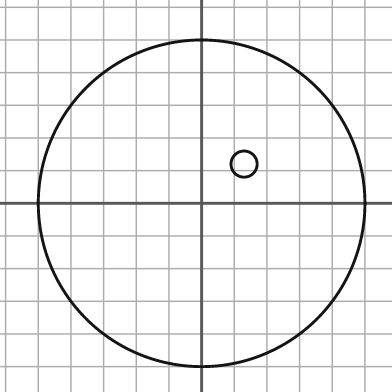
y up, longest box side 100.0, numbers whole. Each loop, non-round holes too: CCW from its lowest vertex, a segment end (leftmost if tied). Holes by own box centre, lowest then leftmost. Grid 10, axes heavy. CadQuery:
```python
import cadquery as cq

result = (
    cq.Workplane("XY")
    .moveTo(0.0, 0.0)
    .circle(50.0)
    .moveTo(13.0, 12.0)
    .circle(4.0)
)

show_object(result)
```